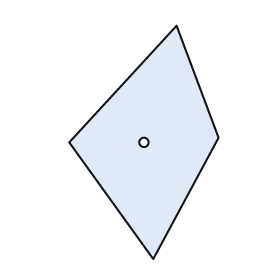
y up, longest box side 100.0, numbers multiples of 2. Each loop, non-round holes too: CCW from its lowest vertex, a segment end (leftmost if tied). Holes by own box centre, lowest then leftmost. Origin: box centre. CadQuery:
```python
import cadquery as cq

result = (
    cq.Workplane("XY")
    .moveTo(4.0, -50.0)
    .lineTo(32.0, 2.0)
    .lineTo(14.0, 50.0)
    .lineTo(-32.0, 0.0)
    .close()
    .moveTo(0.0, 0.0)
    .circle(2.0)
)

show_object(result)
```